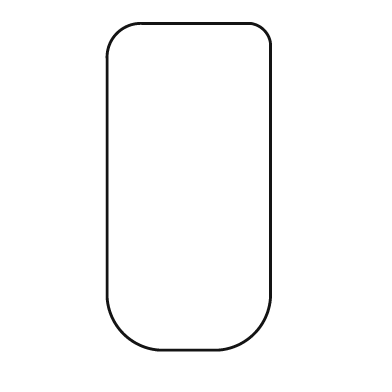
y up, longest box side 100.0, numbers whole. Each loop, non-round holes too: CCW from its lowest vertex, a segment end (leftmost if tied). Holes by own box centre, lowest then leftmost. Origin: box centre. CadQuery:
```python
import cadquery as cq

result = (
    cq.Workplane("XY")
    .moveTo(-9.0, -50.0)
    .lineTo(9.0, -50.0)
    .threePointArc((20.0, -45.0), (25.0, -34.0))
    .lineTo(25.0, 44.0)
    .threePointArc((23.0, 48.0), (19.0, 50.0))
    .lineTo(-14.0, 50.0)
    .threePointArc((-22.0, 47.0), (-25.0, 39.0))
    .lineTo(-25.0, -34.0)
    .threePointArc((-20.0, -45.0), (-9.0, -50.0))
    .close()
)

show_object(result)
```